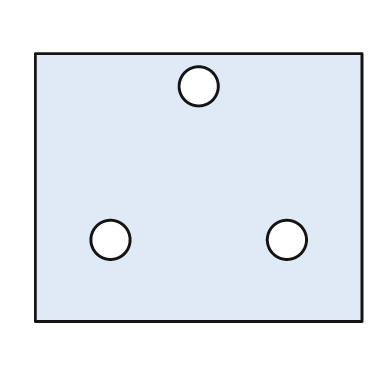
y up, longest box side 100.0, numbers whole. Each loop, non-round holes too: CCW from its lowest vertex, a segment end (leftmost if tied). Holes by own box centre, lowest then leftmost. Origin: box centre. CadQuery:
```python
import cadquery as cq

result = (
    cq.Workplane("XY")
    .moveTo(-50.0, -41.0)
    .lineTo(50.0, -41.0)
    .lineTo(50.0, 41.0)
    .lineTo(-50.0, 41.0)
    .close()
    .moveTo(-27.0, -16.0)
    .circle(6.0)
    .moveTo(27.0, -16.0)
    .circle(6.0)
    .moveTo(0.0, 31.0)
    .circle(6.0)
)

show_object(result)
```